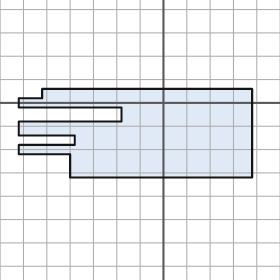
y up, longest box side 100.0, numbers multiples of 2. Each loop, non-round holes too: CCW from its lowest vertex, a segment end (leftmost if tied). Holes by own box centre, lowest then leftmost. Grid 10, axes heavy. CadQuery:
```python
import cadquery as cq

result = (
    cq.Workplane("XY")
    .moveTo(-40.0, -32.0)
    .lineTo(38.0, -32.0)
    .lineTo(38.0, 6.0)
    .lineTo(-52.0, 6.0)
    .lineTo(-52.0, 2.0)
    .lineTo(-62.0, 2.0)
    .lineTo(-62.0, -2.0)
    .lineTo(-18.0, -2.0)
    .lineTo(-18.0, -8.0)
    .lineTo(-62.0, -8.0)
    .lineTo(-62.0, -14.0)
    .lineTo(-38.0, -14.0)
    .lineTo(-38.0, -18.0)
    .lineTo(-62.0, -18.0)
    .lineTo(-62.0, -22.0)
    .lineTo(-40.0, -22.0)
    .close()
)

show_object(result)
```